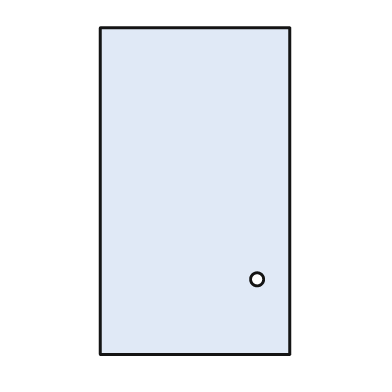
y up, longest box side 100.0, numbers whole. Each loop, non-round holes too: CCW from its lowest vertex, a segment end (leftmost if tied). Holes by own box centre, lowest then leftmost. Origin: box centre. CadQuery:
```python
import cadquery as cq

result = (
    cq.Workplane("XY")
    .moveTo(-29.0, -50.0)
    .lineTo(29.0, -50.0)
    .lineTo(29.0, 50.0)
    .lineTo(-29.0, 50.0)
    .close()
    .moveTo(19.0, -27.0)
    .circle(2.0)
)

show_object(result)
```